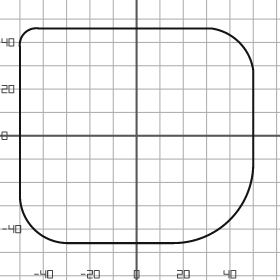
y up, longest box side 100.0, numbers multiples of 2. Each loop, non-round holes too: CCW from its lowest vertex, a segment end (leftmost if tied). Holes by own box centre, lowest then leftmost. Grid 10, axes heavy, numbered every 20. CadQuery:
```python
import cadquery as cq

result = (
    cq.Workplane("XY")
    .moveTo(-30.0, -46.0)
    .lineTo(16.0, -46.0)
    .threePointArc((40.0, -36.0), (50.0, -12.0))
    .lineTo(50.0, 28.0)
    .threePointArc((44.0, 40.0), (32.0, 46.0))
    .lineTo(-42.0, 46.0)
    .threePointArc((-48.0, 44.0), (-50.0, 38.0))
    .lineTo(-50.0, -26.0)
    .threePointArc((-44.0, -40.0), (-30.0, -46.0))
    .close()
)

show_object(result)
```